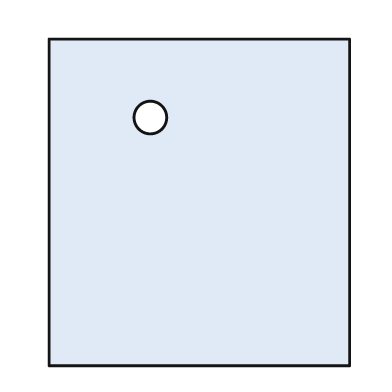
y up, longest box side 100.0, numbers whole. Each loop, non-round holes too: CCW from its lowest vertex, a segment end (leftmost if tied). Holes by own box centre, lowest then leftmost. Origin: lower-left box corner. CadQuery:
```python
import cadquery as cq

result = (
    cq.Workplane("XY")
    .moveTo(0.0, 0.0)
    .lineTo(92.0, 0.0)
    .lineTo(92.0, 100.0)
    .lineTo(0.0, 100.0)
    .close()
    .moveTo(31.0, 76.0)
    .circle(5.0)
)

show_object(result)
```